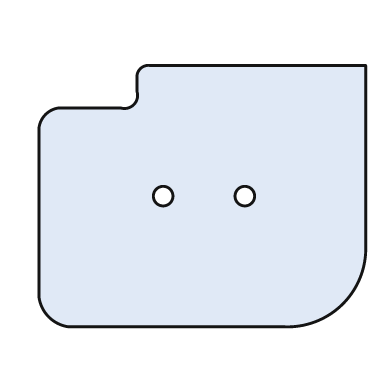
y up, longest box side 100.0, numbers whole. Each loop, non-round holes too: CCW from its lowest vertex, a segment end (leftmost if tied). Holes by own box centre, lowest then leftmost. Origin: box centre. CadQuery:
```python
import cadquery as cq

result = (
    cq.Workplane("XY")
    .moveTo(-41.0, -40.0)
    .lineTo(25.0, -40.0)
    .threePointArc((43.0, -33.0), (50.0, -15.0))
    .lineTo(50.0, 40.0)
    .lineTo(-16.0, 40.0)
    .threePointArc((-19.0, 39.0), (-20.0, 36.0))
    .lineTo(-20.0, 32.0)
    .threePointArc((-21.0, 28.0), (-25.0, 27.0))
    .lineTo(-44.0, 27.0)
    .threePointArc((-48.0, 25.0), (-50.0, 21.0))
    .lineTo(-50.0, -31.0)
    .threePointArc((-47.0, -37.0), (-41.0, -40.0))
    .close()
    .moveTo(-12.0, 0.0)
    .circle(3.0)
    .moveTo(13.0, 0.0)
    .circle(3.0)
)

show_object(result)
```